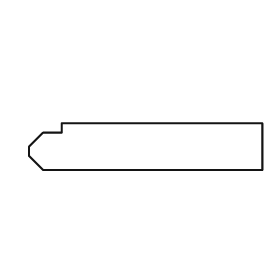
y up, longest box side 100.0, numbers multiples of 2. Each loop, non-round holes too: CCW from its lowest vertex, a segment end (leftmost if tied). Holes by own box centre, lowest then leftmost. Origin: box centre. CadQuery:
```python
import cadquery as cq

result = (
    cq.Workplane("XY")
    .moveTo(-44.0, -10.0)
    .lineTo(50.0, -10.0)
    .lineTo(50.0, 10.0)
    .lineTo(-36.0, 10.0)
    .lineTo(-36.0, 6.0)
    .lineTo(-44.0, 6.0)
    .lineTo(-50.0, 0.0)
    .lineTo(-50.0, -4.0)
    .close()
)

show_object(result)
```